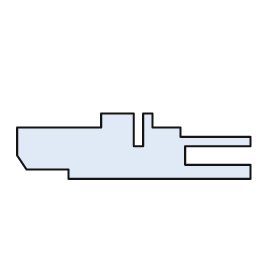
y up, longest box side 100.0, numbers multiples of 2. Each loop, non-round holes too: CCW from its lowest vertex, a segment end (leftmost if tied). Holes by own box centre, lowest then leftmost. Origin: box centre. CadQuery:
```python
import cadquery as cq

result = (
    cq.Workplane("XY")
    .moveTo(-28.0, -14.0)
    .lineTo(50.0, -14.0)
    .lineTo(50.0, -8.0)
    .lineTo(22.0, -8.0)
    .lineTo(22.0, 0.0)
    .lineTo(50.0, 0.0)
    .lineTo(50.0, 4.0)
    .lineTo(20.0, 4.0)
    .lineTo(20.0, 8.0)
    .lineTo(8.0, 8.0)
    .lineTo(8.0, 14.0)
    .lineTo(4.0, 14.0)
    .lineTo(4.0, 0.0)
    .lineTo(0.0, 0.0)
    .lineTo(0.0, 14.0)
    .lineTo(-14.0, 14.0)
    .lineTo(-14.0, 8.0)
    .lineTo(-50.0, 8.0)
    .lineTo(-50.0, -4.0)
    .lineTo(-46.0, -10.0)
    .lineTo(-28.0, -10.0)
    .close()
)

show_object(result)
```